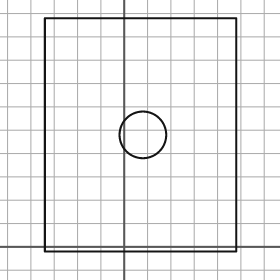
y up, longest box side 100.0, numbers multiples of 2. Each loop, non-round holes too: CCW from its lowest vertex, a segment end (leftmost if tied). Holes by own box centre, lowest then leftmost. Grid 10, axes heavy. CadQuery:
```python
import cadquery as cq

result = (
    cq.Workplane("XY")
    .moveTo(-34.0, -2.0)
    .lineTo(48.0, -2.0)
    .lineTo(48.0, 98.0)
    .lineTo(-34.0, 98.0)
    .close()
    .moveTo(8.0, 48.0)
    .circle(10.0)
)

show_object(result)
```